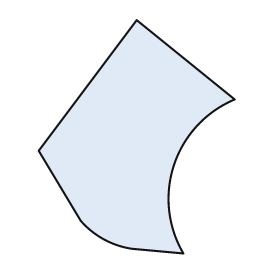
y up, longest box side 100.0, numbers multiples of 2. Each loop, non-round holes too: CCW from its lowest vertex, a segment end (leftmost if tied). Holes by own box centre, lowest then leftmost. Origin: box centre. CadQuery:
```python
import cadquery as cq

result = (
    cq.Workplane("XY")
    .moveTo(20.0, -50.0)
    .threePointArc((16.0, -12.0), (42.0, 16.0))
    .lineTo(0.0, 50.0)
    .lineTo(-42.0, -6.0)
    .lineTo(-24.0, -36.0)
    .threePointArc((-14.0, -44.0), (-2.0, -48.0))
    .close()
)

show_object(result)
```